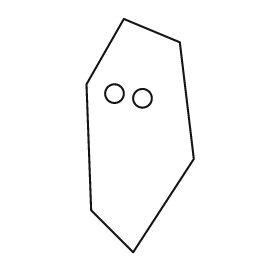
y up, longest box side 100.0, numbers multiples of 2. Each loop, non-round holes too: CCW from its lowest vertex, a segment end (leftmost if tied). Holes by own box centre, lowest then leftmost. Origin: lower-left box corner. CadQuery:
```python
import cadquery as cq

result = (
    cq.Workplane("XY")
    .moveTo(20.0, 0.0)
    .lineTo(46.0, 40.0)
    .lineTo(40.0, 90.0)
    .lineTo(16.0, 100.0)
    .lineTo(0.0, 72.0)
    .lineTo(2.0, 18.0)
    .close()
    .moveTo(24.0, 66.0)
    .circle(4.0)
    .moveTo(12.0, 68.0)
    .circle(4.0)
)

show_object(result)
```